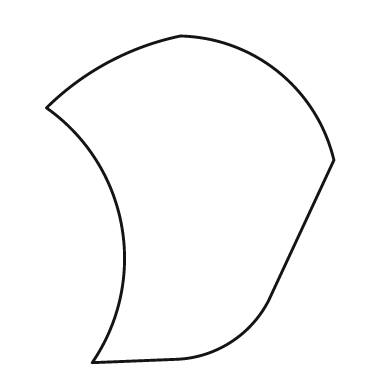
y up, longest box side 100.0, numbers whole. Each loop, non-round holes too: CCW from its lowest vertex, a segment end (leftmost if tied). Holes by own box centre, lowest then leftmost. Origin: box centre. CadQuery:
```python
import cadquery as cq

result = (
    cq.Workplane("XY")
    .moveTo(-30.0, -50.0)
    .lineTo(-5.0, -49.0)
    .threePointArc((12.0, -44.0), (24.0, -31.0))
    .lineTo(44.0, 12.0)
    .threePointArc((27.0, 39.0), (-3.0, 50.0))
    .threePointArc((-25.0, 42.0), (-44.0, 28.0))
    .threePointArc((-21.0, -8.0), (-30.0, -50.0))
    .close()
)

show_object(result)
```